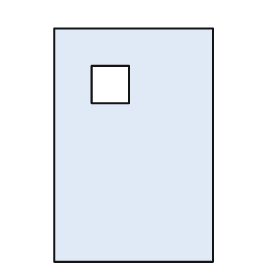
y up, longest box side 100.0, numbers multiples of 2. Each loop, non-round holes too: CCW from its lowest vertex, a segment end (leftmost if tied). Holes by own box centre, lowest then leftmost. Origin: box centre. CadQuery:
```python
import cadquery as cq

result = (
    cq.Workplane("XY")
    .moveTo(-34.0, -50.0)
    .lineTo(34.0, -50.0)
    .lineTo(34.0, 50.0)
    .lineTo(-34.0, 50.0)
    .close()
    .moveTo(-18.0, 18.0)
    .lineTo(-2.0, 18.0)
    .lineTo(-2.0, 34.0)
    .lineTo(-18.0, 34.0)
    .close()
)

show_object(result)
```